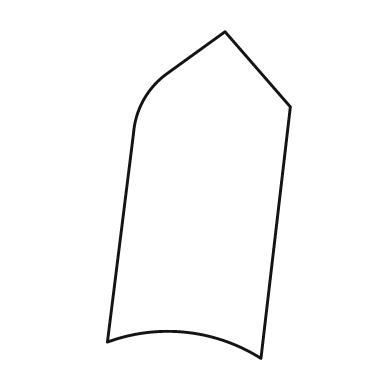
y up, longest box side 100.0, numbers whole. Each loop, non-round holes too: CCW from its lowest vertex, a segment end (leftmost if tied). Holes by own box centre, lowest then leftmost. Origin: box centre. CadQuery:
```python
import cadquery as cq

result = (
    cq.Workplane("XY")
    .moveTo(19.0, -50.0)
    .lineTo(28.0, 27.0)
    .lineTo(8.0, 50.0)
    .lineTo(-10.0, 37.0)
    .threePointArc((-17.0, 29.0), (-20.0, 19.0))
    .lineTo(-28.0, -45.0)
    .threePointArc((-4.0, -42.0), (19.0, -50.0))
    .close()
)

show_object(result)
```